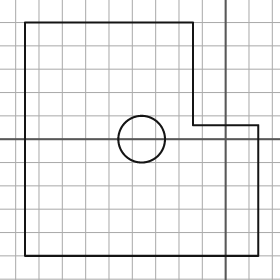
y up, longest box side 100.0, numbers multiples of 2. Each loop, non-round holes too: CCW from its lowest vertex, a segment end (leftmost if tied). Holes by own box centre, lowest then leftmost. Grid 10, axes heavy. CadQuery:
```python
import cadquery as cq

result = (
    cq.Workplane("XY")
    .moveTo(-86.0, -50.0)
    .lineTo(14.0, -50.0)
    .lineTo(14.0, 6.0)
    .lineTo(-14.0, 6.0)
    .lineTo(-14.0, 50.0)
    .lineTo(-86.0, 50.0)
    .close()
    .moveTo(-36.0, 0.0)
    .circle(10.0)
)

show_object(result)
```